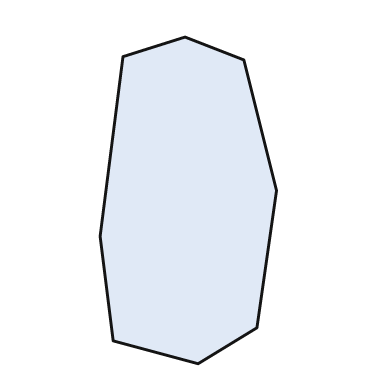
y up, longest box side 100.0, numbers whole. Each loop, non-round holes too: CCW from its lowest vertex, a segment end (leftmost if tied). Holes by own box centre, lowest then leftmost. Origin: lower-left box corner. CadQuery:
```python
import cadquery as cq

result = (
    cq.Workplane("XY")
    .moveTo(30.0, 0.0)
    .lineTo(48.0, 11.0)
    .lineTo(54.0, 53.0)
    .lineTo(44.0, 93.0)
    .lineTo(26.0, 100.0)
    .lineTo(7.0, 94.0)
    .lineTo(0.0, 39.0)
    .lineTo(4.0, 7.0)
    .close()
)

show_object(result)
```